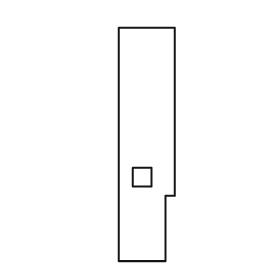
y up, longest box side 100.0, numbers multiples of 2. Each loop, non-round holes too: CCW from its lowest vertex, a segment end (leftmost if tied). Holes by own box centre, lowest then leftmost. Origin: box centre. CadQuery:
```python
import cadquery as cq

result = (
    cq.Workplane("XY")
    .moveTo(-12.0, -50.0)
    .lineTo(8.0, -50.0)
    .lineTo(8.0, -22.0)
    .lineTo(12.0, -22.0)
    .lineTo(12.0, 50.0)
    .lineTo(-12.0, 50.0)
    .close()
    .moveTo(-6.0, -18.0)
    .lineTo(2.0, -18.0)
    .lineTo(2.0, -10.0)
    .lineTo(-6.0, -10.0)
    .close()
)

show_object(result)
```